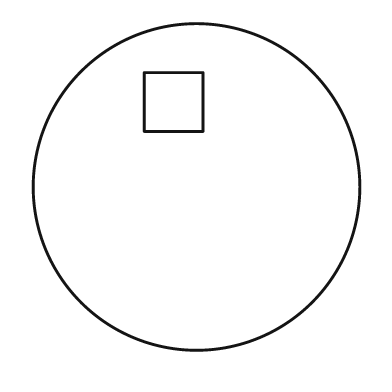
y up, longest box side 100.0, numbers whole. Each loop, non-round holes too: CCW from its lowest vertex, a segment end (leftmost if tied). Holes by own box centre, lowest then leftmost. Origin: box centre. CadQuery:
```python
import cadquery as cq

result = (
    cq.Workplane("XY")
    .moveTo(0.0, 0.0)
    .circle(50.0)
    .moveTo(-16.0, 17.0)
    .lineTo(2.0, 17.0)
    .lineTo(2.0, 35.0)
    .lineTo(-16.0, 35.0)
    .close()
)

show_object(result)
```